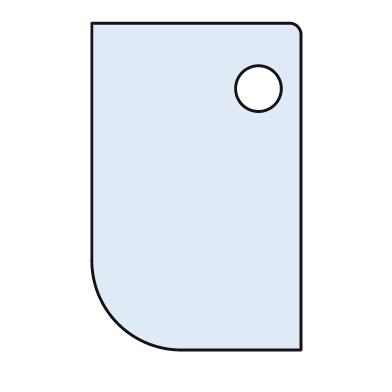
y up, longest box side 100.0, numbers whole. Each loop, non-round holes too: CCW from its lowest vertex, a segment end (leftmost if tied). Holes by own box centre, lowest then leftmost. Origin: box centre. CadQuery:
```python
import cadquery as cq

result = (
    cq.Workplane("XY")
    .moveTo(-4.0, -50.0)
    .lineTo(32.0, -50.0)
    .lineTo(32.0, 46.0)
    .threePointArc((31.0, 49.0), (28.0, 50.0))
    .lineTo(-32.0, 50.0)
    .lineTo(-32.0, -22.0)
    .threePointArc((-24.0, -42.0), (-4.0, -50.0))
    .close()
    .moveTo(19.0, 30.0)
    .circle(7.0)
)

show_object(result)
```